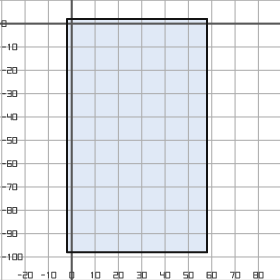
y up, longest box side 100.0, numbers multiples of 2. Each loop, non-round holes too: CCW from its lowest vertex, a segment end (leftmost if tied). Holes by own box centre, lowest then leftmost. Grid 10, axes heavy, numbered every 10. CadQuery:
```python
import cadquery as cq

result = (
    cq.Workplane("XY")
    .moveTo(-2.0, -98.0)
    .lineTo(58.0, -98.0)
    .lineTo(58.0, 2.0)
    .lineTo(-2.0, 2.0)
    .close()
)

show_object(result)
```